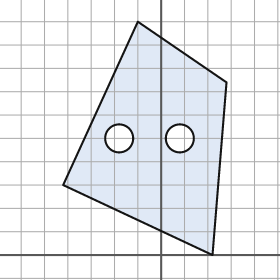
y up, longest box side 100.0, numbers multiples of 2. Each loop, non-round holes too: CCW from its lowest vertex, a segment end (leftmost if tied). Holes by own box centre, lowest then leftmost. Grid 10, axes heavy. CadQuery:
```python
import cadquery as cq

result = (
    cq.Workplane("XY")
    .moveTo(22.0, 0.0)
    .lineTo(28.0, 74.0)
    .lineTo(-10.0, 100.0)
    .lineTo(-42.0, 30.0)
    .close()
    .moveTo(-18.0, 50.0)
    .circle(6.0)
    .moveTo(8.0, 50.0)
    .circle(6.0)
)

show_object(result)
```